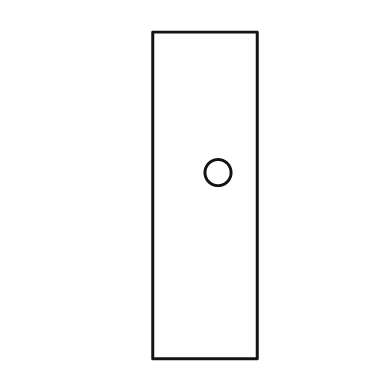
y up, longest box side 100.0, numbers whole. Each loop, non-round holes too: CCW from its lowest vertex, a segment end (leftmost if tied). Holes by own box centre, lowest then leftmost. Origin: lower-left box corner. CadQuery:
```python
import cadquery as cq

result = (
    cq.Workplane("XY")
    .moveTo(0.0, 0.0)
    .lineTo(32.0, 0.0)
    .lineTo(32.0, 100.0)
    .lineTo(0.0, 100.0)
    .close()
    .moveTo(20.0, 57.0)
    .circle(4.0)
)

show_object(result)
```